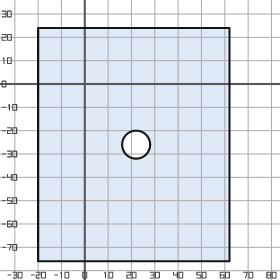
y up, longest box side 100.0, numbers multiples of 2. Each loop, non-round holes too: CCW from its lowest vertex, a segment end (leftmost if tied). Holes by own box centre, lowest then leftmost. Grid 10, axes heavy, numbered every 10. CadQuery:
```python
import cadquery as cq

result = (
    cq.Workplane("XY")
    .moveTo(-20.0, -76.0)
    .lineTo(62.0, -76.0)
    .lineTo(62.0, 24.0)
    .lineTo(-20.0, 24.0)
    .close()
    .moveTo(22.0, -26.0)
    .circle(6.0)
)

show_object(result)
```